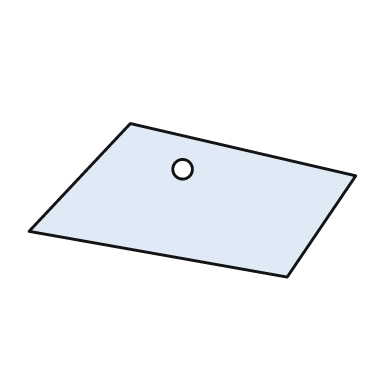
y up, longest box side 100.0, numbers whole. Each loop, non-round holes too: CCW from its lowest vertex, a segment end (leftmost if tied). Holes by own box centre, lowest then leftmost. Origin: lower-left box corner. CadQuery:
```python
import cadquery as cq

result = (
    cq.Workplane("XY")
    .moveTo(79.0, 0.0)
    .lineTo(100.0, 31.0)
    .lineTo(31.0, 47.0)
    .lineTo(0.0, 14.0)
    .close()
    .moveTo(47.0, 33.0)
    .circle(3.0)
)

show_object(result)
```